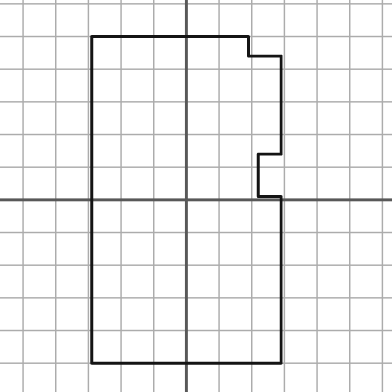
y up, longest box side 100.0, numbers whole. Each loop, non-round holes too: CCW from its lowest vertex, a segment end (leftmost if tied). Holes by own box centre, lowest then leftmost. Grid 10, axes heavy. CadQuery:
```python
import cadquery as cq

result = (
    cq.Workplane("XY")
    .moveTo(-29.0, -50.0)
    .lineTo(29.0, -50.0)
    .lineTo(29.0, 1.0)
    .lineTo(22.0, 1.0)
    .lineTo(22.0, 14.0)
    .lineTo(29.0, 14.0)
    .lineTo(29.0, 44.0)
    .lineTo(19.0, 44.0)
    .lineTo(19.0, 50.0)
    .lineTo(-29.0, 50.0)
    .close()
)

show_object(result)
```